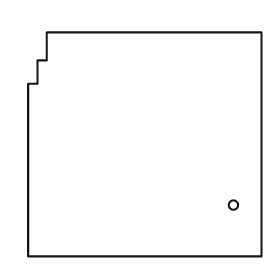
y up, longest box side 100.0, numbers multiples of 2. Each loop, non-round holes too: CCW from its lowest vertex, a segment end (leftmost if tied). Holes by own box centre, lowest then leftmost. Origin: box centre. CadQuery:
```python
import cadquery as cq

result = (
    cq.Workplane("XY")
    .moveTo(-50.0, -48.0)
    .lineTo(50.0, -48.0)
    .lineTo(50.0, 48.0)
    .lineTo(-42.0, 48.0)
    .lineTo(-42.0, 36.0)
    .lineTo(-46.0, 36.0)
    .lineTo(-46.0, 26.0)
    .lineTo(-50.0, 26.0)
    .close()
    .moveTo(38.0, -26.0)
    .circle(2.0)
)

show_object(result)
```